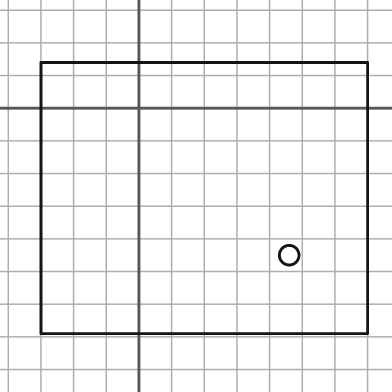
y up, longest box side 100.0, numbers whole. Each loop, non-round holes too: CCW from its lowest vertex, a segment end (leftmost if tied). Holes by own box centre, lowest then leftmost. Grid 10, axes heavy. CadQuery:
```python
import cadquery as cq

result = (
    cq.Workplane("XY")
    .moveTo(-30.0, -69.0)
    .lineTo(70.0, -69.0)
    .lineTo(70.0, 14.0)
    .lineTo(-30.0, 14.0)
    .close()
    .moveTo(46.0, -45.0)
    .circle(3.0)
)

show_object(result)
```